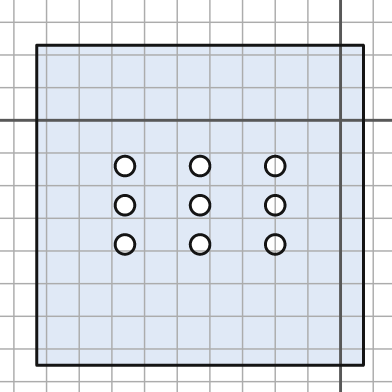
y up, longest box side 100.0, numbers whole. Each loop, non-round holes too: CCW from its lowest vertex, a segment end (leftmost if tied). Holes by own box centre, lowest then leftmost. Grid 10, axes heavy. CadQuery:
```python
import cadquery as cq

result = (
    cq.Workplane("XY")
    .moveTo(-93.0, -75.0)
    .lineTo(7.0, -75.0)
    .lineTo(7.0, 23.0)
    .lineTo(-93.0, 23.0)
    .close()
    .moveTo(-66.0, -38.0)
    .circle(3.0)
    .moveTo(-43.0, -38.0)
    .circle(3.0)
    .moveTo(-20.0, -38.0)
    .circle(3.0)
    .moveTo(-66.0, -26.0)
    .circle(3.0)
    .moveTo(-43.0, -26.0)
    .circle(3.0)
    .moveTo(-20.0, -26.0)
    .circle(3.0)
    .moveTo(-66.0, -14.0)
    .circle(3.0)
    .moveTo(-43.0, -14.0)
    .circle(3.0)
    .moveTo(-20.0, -14.0)
    .circle(3.0)
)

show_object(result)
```